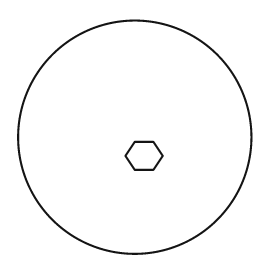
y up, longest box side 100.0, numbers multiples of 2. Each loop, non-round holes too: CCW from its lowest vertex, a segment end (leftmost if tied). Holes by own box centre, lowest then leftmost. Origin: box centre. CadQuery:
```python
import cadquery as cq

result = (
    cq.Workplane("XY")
    .moveTo(0.0, 0.0)
    .circle(50.0)
    .moveTo(0.0, -14.0)
    .lineTo(8.0, -14.0)
    .lineTo(12.0, -8.0)
    .lineTo(8.0, -2.0)
    .lineTo(0.0, -2.0)
    .lineTo(-4.0, -8.0)
    .close()
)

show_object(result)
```